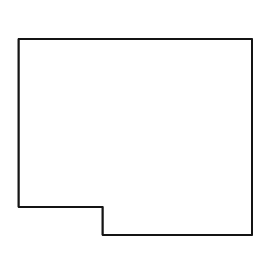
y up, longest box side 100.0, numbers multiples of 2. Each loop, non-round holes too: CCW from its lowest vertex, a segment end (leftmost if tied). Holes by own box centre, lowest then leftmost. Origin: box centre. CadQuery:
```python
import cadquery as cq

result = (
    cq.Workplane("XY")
    .moveTo(-14.0, -42.0)
    .lineTo(50.0, -42.0)
    .lineTo(50.0, 42.0)
    .lineTo(-50.0, 42.0)
    .lineTo(-50.0, -30.0)
    .lineTo(-14.0, -30.0)
    .close()
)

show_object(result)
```